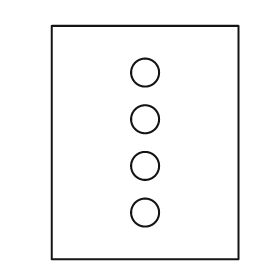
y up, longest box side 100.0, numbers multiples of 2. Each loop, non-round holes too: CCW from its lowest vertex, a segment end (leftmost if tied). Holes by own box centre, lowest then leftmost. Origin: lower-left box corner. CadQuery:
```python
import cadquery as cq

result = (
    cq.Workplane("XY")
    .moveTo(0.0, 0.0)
    .lineTo(80.0, 0.0)
    .lineTo(80.0, 100.0)
    .lineTo(0.0, 100.0)
    .close()
    .moveTo(40.0, 20.0)
    .circle(6.0)
    .moveTo(40.0, 40.0)
    .circle(6.0)
    .moveTo(40.0, 60.0)
    .circle(6.0)
    .moveTo(40.0, 80.0)
    .circle(6.0)
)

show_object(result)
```